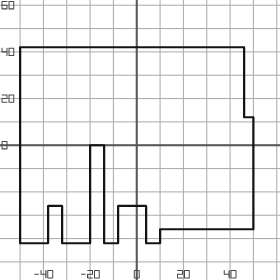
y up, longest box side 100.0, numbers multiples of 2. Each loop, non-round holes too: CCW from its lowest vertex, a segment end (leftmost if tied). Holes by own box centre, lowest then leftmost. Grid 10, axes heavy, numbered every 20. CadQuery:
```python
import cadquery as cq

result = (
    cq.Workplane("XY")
    .moveTo(-50.0, -42.0)
    .lineTo(-38.0, -42.0)
    .lineTo(-38.0, -26.0)
    .lineTo(-32.0, -26.0)
    .lineTo(-32.0, -42.0)
    .lineTo(-20.0, -42.0)
    .lineTo(-20.0, 0.0)
    .lineTo(-14.0, 0.0)
    .lineTo(-14.0, -42.0)
    .lineTo(-8.0, -42.0)
    .lineTo(-8.0, -26.0)
    .lineTo(4.0, -26.0)
    .lineTo(4.0, -42.0)
    .lineTo(10.0, -42.0)
    .lineTo(10.0, -36.0)
    .lineTo(50.0, -36.0)
    .lineTo(50.0, 12.0)
    .lineTo(46.0, 12.0)
    .lineTo(46.0, 42.0)
    .lineTo(-50.0, 42.0)
    .close()
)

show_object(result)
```